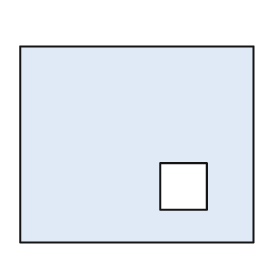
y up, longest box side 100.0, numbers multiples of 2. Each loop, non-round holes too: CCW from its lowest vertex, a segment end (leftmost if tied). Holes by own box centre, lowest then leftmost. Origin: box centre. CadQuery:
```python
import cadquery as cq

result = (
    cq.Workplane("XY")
    .moveTo(-50.0, -42.0)
    .lineTo(50.0, -42.0)
    .lineTo(50.0, 42.0)
    .lineTo(-50.0, 42.0)
    .close()
    .moveTo(10.0, -28.0)
    .lineTo(30.0, -28.0)
    .lineTo(30.0, -8.0)
    .lineTo(10.0, -8.0)
    .close()
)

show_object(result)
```